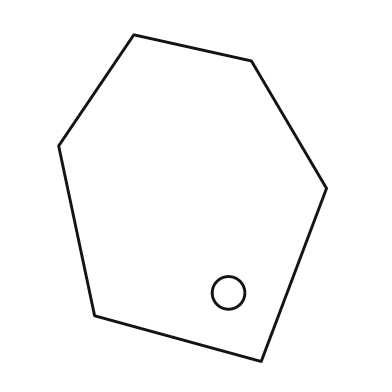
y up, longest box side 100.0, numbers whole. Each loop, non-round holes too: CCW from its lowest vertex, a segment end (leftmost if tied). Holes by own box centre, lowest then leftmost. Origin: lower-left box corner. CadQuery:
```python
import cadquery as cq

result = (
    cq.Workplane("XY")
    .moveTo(62.0, 0.0)
    .lineTo(82.0, 53.0)
    .lineTo(59.0, 92.0)
    .lineTo(23.0, 100.0)
    .lineTo(0.0, 66.0)
    .lineTo(11.0, 14.0)
    .close()
    .moveTo(52.0, 21.0)
    .circle(5.0)
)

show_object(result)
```